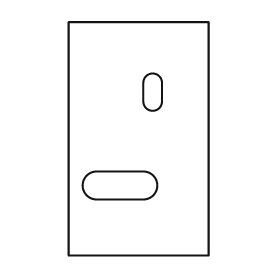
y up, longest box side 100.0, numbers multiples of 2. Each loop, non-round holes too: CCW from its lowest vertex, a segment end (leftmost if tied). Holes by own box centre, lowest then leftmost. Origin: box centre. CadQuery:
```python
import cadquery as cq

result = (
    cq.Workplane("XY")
    .moveTo(-30.0, -50.0)
    .lineTo(30.0, -50.0)
    .lineTo(30.0, 50.0)
    .lineTo(-30.0, 50.0)
    .close()
    .moveTo(-18.0, -26.0)
    .lineTo(2.0, -26.0)
    .threePointArc((8.0, -20.0), (2.0, -14.0))
    .lineTo(-18.0, -14.0)
    .threePointArc((-24.0, -20.0), (-18.0, -26.0))
    .close()
    .moveTo(2.0, 16.0)
    .threePointArc((6.0, 12.0), (10.0, 16.0))
    .lineTo(10.0, 24.0)
    .threePointArc((6.0, 28.0), (2.0, 24.0))
    .close()
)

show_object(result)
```